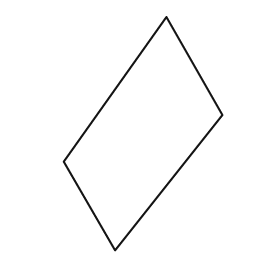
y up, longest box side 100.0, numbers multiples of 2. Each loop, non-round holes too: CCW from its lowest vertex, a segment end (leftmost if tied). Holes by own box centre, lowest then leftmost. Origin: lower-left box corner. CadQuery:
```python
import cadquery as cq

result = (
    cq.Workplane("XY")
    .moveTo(22.0, 0.0)
    .lineTo(68.0, 58.0)
    .lineTo(44.0, 100.0)
    .lineTo(0.0, 38.0)
    .close()
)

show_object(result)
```